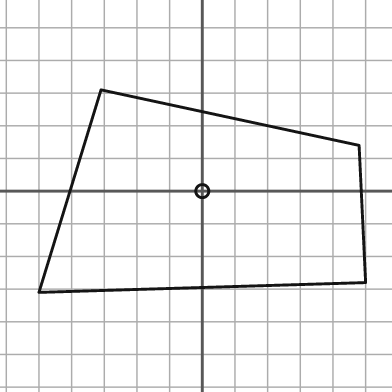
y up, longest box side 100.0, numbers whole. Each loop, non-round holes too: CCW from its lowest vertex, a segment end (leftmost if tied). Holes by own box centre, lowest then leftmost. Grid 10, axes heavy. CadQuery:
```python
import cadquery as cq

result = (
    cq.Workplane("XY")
    .moveTo(-50.0, -31.0)
    .lineTo(50.0, -28.0)
    .lineTo(48.0, 14.0)
    .lineTo(-31.0, 31.0)
    .close()
    .moveTo(0.0, 0.0)
    .circle(2.0)
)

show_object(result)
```